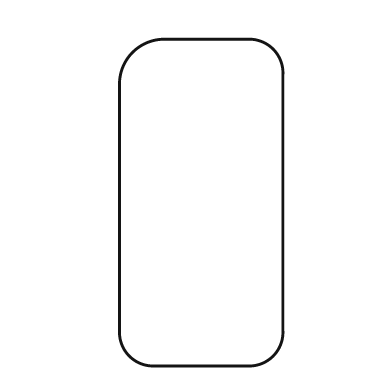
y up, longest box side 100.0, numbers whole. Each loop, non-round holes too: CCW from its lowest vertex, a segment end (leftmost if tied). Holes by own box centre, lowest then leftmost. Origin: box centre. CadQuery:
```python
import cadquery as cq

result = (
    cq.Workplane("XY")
    .moveTo(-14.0, -50.0)
    .lineTo(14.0, -50.0)
    .threePointArc((22.0, -47.0), (25.0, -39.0))
    .lineTo(25.0, 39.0)
    .threePointArc((22.0, 47.0), (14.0, 50.0))
    .lineTo(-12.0, 50.0)
    .threePointArc((-21.0, 46.0), (-25.0, 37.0))
    .lineTo(-25.0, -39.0)
    .threePointArc((-22.0, -47.0), (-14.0, -50.0))
    .close()
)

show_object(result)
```